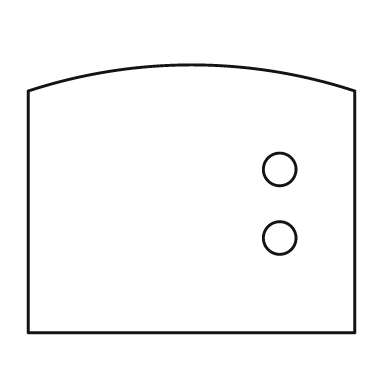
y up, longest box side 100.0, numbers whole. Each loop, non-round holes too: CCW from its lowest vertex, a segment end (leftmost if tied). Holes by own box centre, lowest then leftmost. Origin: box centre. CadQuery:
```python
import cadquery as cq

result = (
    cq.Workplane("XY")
    .moveTo(-50.0, -41.0)
    .lineTo(50.0, -41.0)
    .lineTo(50.0, 33.0)
    .threePointArc((0.0, 41.0), (-50.0, 33.0))
    .close()
    .moveTo(27.0, -12.0)
    .circle(5.0)
    .moveTo(27.0, 9.0)
    .circle(5.0)
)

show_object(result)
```